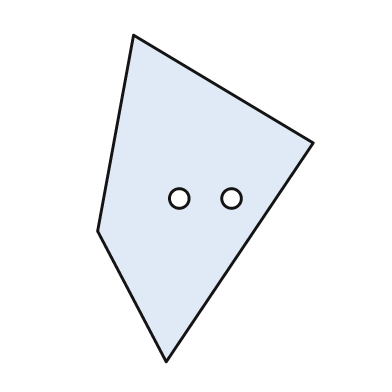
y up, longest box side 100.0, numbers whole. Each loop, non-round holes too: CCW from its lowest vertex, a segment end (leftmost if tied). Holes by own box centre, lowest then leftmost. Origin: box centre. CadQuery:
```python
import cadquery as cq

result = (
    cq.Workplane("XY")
    .moveTo(-12.0, -50.0)
    .lineTo(33.0, 17.0)
    .lineTo(-22.0, 50.0)
    .lineTo(-33.0, -10.0)
    .close()
    .moveTo(-8.0, 0.0)
    .circle(3.0)
    .moveTo(8.0, 0.0)
    .circle(3.0)
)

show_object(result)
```